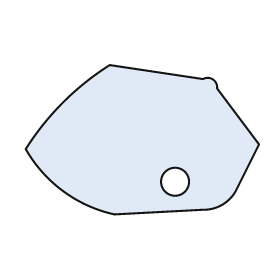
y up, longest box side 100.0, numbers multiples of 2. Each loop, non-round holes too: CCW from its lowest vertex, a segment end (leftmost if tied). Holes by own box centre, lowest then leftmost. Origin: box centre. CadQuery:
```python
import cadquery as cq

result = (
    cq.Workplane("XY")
    .moveTo(-12.0, -32.0)
    .lineTo(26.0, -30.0)
    .threePointArc((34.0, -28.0), (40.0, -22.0))
    .lineTo(50.0, -2.0)
    .lineTo(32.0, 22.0)
    .threePointArc((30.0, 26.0), (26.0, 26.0))
    .lineTo(-14.0, 32.0)
    .threePointArc((-34.0, 16.0), (-50.0, -4.0))
    .threePointArc((-34.0, -22.0), (-12.0, -32.0))
    .close()
    .moveTo(14.0, -18.0)
    .circle(6.0)
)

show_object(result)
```